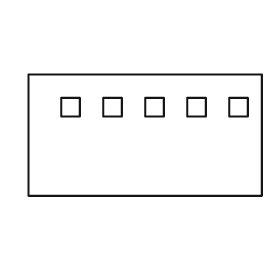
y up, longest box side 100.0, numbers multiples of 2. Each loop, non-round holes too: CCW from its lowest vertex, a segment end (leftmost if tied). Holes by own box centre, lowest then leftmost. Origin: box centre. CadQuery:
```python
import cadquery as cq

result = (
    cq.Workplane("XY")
    .moveTo(-50.0, -26.0)
    .lineTo(50.0, -26.0)
    .lineTo(50.0, 26.0)
    .lineTo(-50.0, 26.0)
    .close()
    .moveTo(-36.0, 8.0)
    .lineTo(-28.0, 8.0)
    .lineTo(-28.0, 16.0)
    .lineTo(-36.0, 16.0)
    .close()
    .moveTo(-18.0, 8.0)
    .lineTo(-10.0, 8.0)
    .lineTo(-10.0, 16.0)
    .lineTo(-18.0, 16.0)
    .close()
    .moveTo(0.0, 8.0)
    .lineTo(8.0, 8.0)
    .lineTo(8.0, 16.0)
    .lineTo(0.0, 16.0)
    .close()
    .moveTo(18.0, 8.0)
    .lineTo(26.0, 8.0)
    .lineTo(26.0, 16.0)
    .lineTo(18.0, 16.0)
    .close()
    .moveTo(36.0, 8.0)
    .lineTo(44.0, 8.0)
    .lineTo(44.0, 16.0)
    .lineTo(36.0, 16.0)
    .close()
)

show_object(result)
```